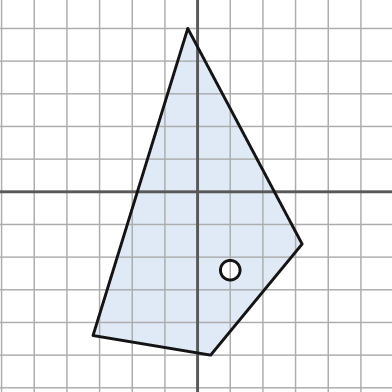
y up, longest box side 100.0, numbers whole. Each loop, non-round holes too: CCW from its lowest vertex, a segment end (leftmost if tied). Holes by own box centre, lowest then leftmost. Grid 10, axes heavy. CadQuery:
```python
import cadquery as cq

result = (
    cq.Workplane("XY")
    .moveTo(4.0, -50.0)
    .lineTo(32.0, -16.0)
    .lineTo(-3.0, 50.0)
    .lineTo(-32.0, -44.0)
    .close()
    .moveTo(10.0, -24.0)
    .circle(3.0)
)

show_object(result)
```